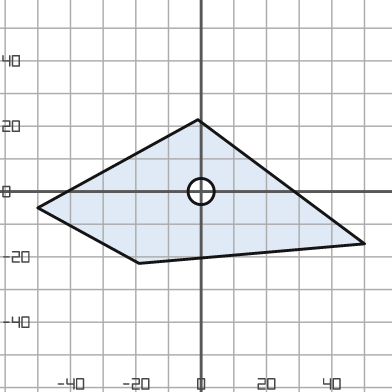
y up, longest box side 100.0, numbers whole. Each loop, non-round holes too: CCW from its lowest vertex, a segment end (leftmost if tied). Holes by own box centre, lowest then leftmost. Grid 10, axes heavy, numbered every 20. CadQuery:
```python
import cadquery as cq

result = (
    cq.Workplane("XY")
    .moveTo(-19.0, -22.0)
    .lineTo(50.0, -16.0)
    .lineTo(-1.0, 22.0)
    .lineTo(-50.0, -5.0)
    .close()
    .moveTo(0.0, 0.0)
    .circle(4.0)
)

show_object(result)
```